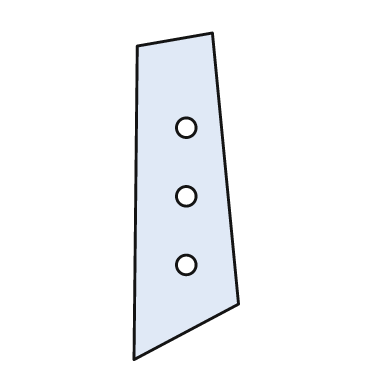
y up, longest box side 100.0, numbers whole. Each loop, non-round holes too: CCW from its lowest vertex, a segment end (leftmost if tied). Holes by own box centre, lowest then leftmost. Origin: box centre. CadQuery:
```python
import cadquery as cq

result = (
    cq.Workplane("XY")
    .moveTo(-16.0, -50.0)
    .lineTo(16.0, -33.0)
    .lineTo(8.0, 50.0)
    .lineTo(-15.0, 46.0)
    .close()
    .moveTo(0.0, -21.0)
    .circle(3.0)
    .moveTo(0.0, 0.0)
    .circle(3.0)
    .moveTo(0.0, 21.0)
    .circle(3.0)
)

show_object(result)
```